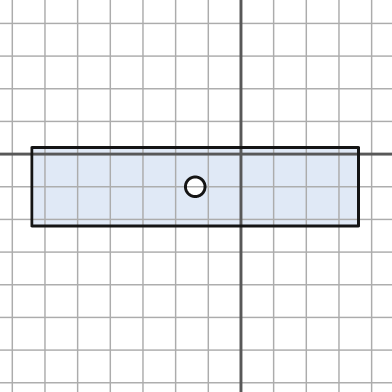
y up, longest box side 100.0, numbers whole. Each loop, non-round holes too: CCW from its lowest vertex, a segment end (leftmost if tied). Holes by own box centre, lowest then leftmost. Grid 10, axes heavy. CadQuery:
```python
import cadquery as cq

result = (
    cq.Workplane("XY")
    .moveTo(-64.0, -22.0)
    .lineTo(36.0, -22.0)
    .lineTo(36.0, 2.0)
    .lineTo(-64.0, 2.0)
    .close()
    .moveTo(-14.0, -10.0)
    .circle(3.0)
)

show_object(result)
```